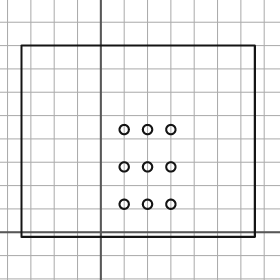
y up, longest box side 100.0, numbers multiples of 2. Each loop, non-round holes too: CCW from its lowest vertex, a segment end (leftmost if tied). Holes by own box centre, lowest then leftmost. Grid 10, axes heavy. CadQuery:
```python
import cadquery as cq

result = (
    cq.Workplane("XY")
    .moveTo(-34.0, -2.0)
    .lineTo(66.0, -2.0)
    .lineTo(66.0, 80.0)
    .lineTo(-34.0, 80.0)
    .close()
    .moveTo(10.0, 12.0)
    .circle(2.0)
    .moveTo(20.0, 12.0)
    .circle(2.0)
    .moveTo(30.0, 12.0)
    .circle(2.0)
    .moveTo(10.0, 28.0)
    .circle(2.0)
    .moveTo(20.0, 28.0)
    .circle(2.0)
    .moveTo(30.0, 28.0)
    .circle(2.0)
    .moveTo(10.0, 44.0)
    .circle(2.0)
    .moveTo(20.0, 44.0)
    .circle(2.0)
    .moveTo(30.0, 44.0)
    .circle(2.0)
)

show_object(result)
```